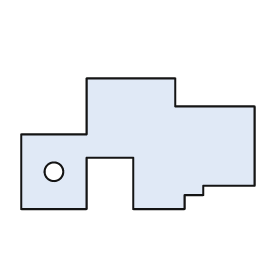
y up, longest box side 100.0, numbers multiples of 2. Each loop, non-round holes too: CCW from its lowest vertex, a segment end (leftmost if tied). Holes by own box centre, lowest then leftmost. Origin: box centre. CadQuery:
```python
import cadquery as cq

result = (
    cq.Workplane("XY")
    .moveTo(-50.0, -28.0)
    .lineTo(-22.0, -28.0)
    .lineTo(-22.0, -6.0)
    .lineTo(-2.0, -6.0)
    .lineTo(-2.0, -28.0)
    .lineTo(20.0, -28.0)
    .lineTo(20.0, -22.0)
    .lineTo(28.0, -22.0)
    .lineTo(28.0, -18.0)
    .lineTo(50.0, -18.0)
    .lineTo(50.0, 16.0)
    .lineTo(16.0, 16.0)
    .lineTo(16.0, 28.0)
    .lineTo(-22.0, 28.0)
    .lineTo(-22.0, 4.0)
    .lineTo(-50.0, 4.0)
    .close()
    .moveTo(-36.0, -12.0)
    .circle(4.0)
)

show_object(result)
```